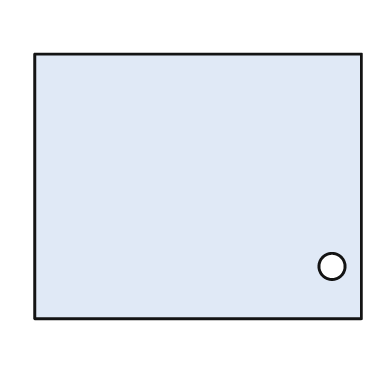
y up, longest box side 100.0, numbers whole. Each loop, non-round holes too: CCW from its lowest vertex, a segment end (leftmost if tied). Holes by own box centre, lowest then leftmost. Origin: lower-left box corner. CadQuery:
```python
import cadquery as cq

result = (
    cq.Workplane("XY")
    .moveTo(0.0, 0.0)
    .lineTo(100.0, 0.0)
    .lineTo(100.0, 81.0)
    .lineTo(0.0, 81.0)
    .close()
    .moveTo(91.0, 16.0)
    .circle(4.0)
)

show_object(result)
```